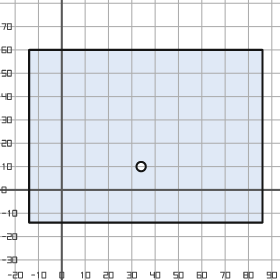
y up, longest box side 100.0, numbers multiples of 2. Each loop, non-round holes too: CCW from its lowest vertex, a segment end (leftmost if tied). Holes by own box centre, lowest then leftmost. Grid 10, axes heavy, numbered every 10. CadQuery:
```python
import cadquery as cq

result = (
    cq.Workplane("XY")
    .moveTo(-14.0, -14.0)
    .lineTo(86.0, -14.0)
    .lineTo(86.0, 60.0)
    .lineTo(-14.0, 60.0)
    .close()
    .moveTo(34.0, 10.0)
    .circle(2.0)
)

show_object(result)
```